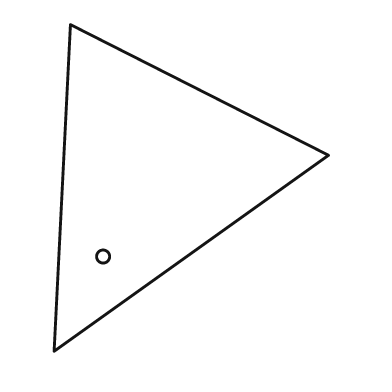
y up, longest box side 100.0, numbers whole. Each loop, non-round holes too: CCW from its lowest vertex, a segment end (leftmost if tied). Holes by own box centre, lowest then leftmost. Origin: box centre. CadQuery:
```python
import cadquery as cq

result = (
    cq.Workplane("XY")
    .moveTo(-42.0, -50.0)
    .lineTo(42.0, 10.0)
    .lineTo(-37.0, 50.0)
    .close()
    .moveTo(-27.0, -21.0)
    .circle(2.0)
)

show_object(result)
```